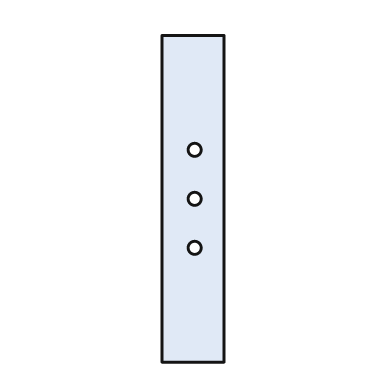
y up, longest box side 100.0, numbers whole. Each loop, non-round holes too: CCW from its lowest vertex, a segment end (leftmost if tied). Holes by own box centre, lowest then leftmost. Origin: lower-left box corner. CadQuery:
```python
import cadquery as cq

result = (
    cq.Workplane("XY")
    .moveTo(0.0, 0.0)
    .lineTo(19.0, 0.0)
    .lineTo(19.0, 100.0)
    .lineTo(0.0, 100.0)
    .close()
    .moveTo(10.0, 35.0)
    .circle(2.0)
    .moveTo(10.0, 50.0)
    .circle(2.0)
    .moveTo(10.0, 65.0)
    .circle(2.0)
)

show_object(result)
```